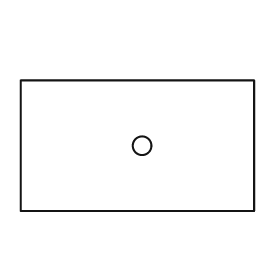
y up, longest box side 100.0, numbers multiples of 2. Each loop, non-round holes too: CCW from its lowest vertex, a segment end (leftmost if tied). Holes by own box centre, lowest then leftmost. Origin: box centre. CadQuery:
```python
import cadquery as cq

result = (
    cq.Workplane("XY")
    .moveTo(-50.0, -28.0)
    .lineTo(50.0, -28.0)
    .lineTo(50.0, 28.0)
    .lineTo(-50.0, 28.0)
    .close()
    .moveTo(2.0, 0.0)
    .circle(4.0)
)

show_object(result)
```